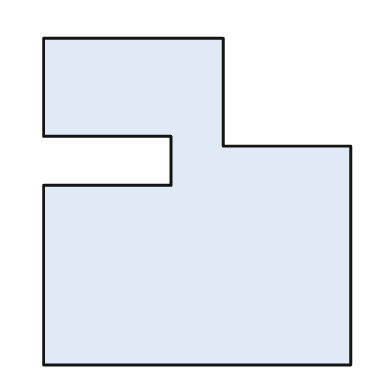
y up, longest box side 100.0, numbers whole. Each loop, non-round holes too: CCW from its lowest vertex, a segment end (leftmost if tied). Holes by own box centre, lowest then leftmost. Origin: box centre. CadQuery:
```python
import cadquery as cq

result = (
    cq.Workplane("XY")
    .moveTo(-47.0, -50.0)
    .lineTo(47.0, -50.0)
    .lineTo(47.0, 17.0)
    .lineTo(8.0, 17.0)
    .lineTo(8.0, 50.0)
    .lineTo(-47.0, 50.0)
    .lineTo(-47.0, 20.0)
    .lineTo(-8.0, 20.0)
    .lineTo(-8.0, 5.0)
    .lineTo(-47.0, 5.0)
    .close()
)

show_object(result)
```